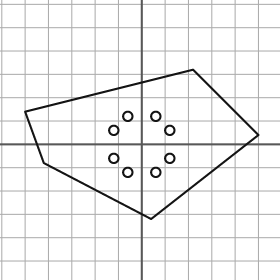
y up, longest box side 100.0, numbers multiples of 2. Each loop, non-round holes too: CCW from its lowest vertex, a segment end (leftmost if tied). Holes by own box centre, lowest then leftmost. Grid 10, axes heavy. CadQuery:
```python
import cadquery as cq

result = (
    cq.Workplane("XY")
    .moveTo(4.0, -32.0)
    .lineTo(50.0, 4.0)
    .lineTo(22.0, 32.0)
    .lineTo(-50.0, 14.0)
    .lineTo(-42.0, -8.0)
    .close()
    .moveTo(-6.0, -12.0)
    .circle(2.0)
    .moveTo(6.0, -12.0)
    .circle(2.0)
    .moveTo(-12.0, -6.0)
    .circle(2.0)
    .moveTo(12.0, -6.0)
    .circle(2.0)
    .moveTo(-12.0, 6.0)
    .circle(2.0)
    .moveTo(12.0, 6.0)
    .circle(2.0)
    .moveTo(-6.0, 12.0)
    .circle(2.0)
    .moveTo(6.0, 12.0)
    .circle(2.0)
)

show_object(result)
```